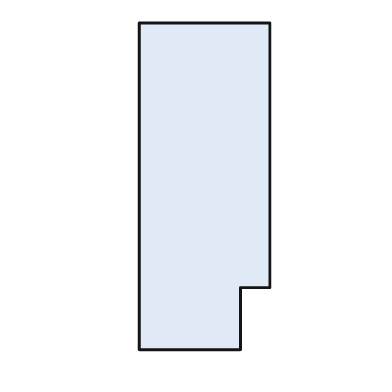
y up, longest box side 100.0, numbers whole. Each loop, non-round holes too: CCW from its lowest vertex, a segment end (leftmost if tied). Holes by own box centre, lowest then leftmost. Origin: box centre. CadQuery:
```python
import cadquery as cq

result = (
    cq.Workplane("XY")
    .moveTo(-20.0, -50.0)
    .lineTo(11.0, -50.0)
    .lineTo(11.0, -31.0)
    .lineTo(20.0, -31.0)
    .lineTo(20.0, 50.0)
    .lineTo(-20.0, 50.0)
    .close()
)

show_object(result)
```